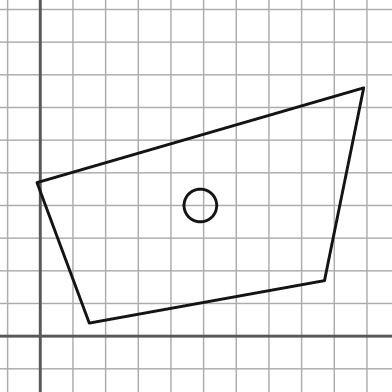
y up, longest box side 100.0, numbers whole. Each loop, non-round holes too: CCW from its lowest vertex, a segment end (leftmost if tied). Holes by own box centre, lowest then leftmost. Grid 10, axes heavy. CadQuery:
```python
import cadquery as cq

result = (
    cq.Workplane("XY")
    .moveTo(15.0, 4.0)
    .lineTo(87.0, 17.0)
    .lineTo(99.0, 76.0)
    .lineTo(-1.0, 47.0)
    .close()
    .moveTo(49.0, 40.0)
    .circle(5.0)
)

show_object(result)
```